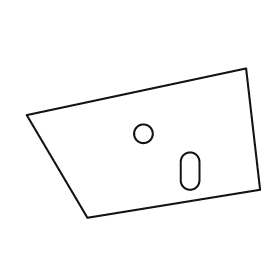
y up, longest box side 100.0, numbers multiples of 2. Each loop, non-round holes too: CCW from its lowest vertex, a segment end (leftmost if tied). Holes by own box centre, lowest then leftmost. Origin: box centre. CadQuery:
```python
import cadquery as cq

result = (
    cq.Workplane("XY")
    .moveTo(-24.0, -32.0)
    .lineTo(50.0, -20.0)
    .lineTo(44.0, 32.0)
    .lineTo(-50.0, 12.0)
    .close()
    .moveTo(16.0, -16.0)
    .threePointArc((20.0, -20.0), (24.0, -16.0))
    .lineTo(24.0, -8.0)
    .threePointArc((20.0, -4.0), (16.0, -8.0))
    .close()
    .moveTo(0.0, 4.0)
    .circle(4.0)
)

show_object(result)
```